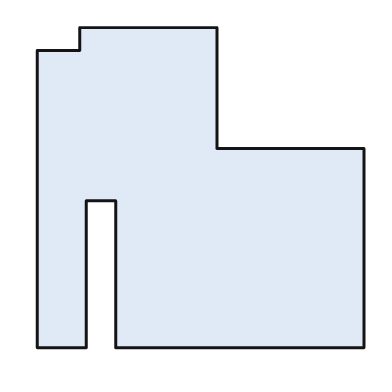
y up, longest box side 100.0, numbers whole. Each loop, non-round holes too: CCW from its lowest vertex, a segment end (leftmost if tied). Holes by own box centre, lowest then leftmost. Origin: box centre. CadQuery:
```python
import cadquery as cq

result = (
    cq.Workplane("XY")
    .moveTo(-50.0, -49.0)
    .lineTo(-35.0, -49.0)
    .lineTo(-35.0, -4.0)
    .lineTo(-26.0, -4.0)
    .lineTo(-26.0, -49.0)
    .lineTo(50.0, -49.0)
    .lineTo(50.0, 12.0)
    .lineTo(5.0, 12.0)
    .lineTo(5.0, 49.0)
    .lineTo(-37.0, 49.0)
    .lineTo(-37.0, 42.0)
    .lineTo(-50.0, 42.0)
    .close()
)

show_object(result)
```